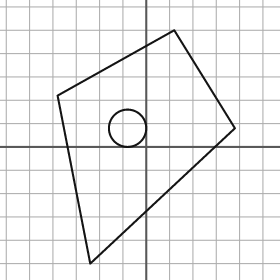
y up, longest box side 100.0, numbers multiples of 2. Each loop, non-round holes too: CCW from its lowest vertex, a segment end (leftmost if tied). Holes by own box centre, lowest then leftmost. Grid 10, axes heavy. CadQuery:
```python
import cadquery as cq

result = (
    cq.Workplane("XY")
    .moveTo(-24.0, -50.0)
    .lineTo(38.0, 8.0)
    .lineTo(12.0, 50.0)
    .lineTo(-38.0, 22.0)
    .close()
    .moveTo(-8.0, 8.0)
    .circle(8.0)
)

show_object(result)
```